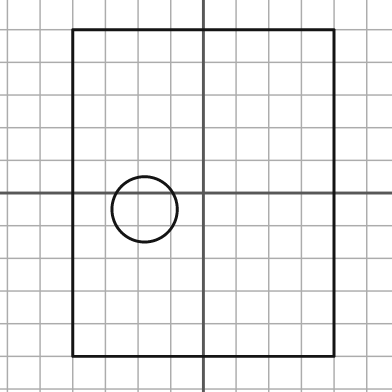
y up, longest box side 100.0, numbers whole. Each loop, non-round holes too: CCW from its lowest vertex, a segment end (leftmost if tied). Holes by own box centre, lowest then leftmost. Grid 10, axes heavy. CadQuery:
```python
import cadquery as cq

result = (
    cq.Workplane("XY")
    .moveTo(-40.0, -50.0)
    .lineTo(40.0, -50.0)
    .lineTo(40.0, 50.0)
    .lineTo(-40.0, 50.0)
    .close()
    .moveTo(-18.0, -5.0)
    .circle(10.0)
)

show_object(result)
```